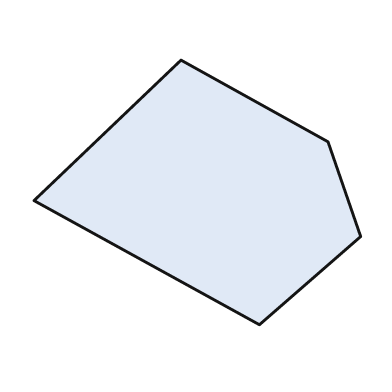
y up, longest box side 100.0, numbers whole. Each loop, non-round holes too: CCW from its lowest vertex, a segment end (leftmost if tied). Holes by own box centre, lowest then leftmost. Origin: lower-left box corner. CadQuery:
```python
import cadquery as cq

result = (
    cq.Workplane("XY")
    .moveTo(69.0, 0.0)
    .lineTo(100.0, 27.0)
    .lineTo(90.0, 56.0)
    .lineTo(45.0, 81.0)
    .lineTo(0.0, 38.0)
    .close()
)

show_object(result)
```